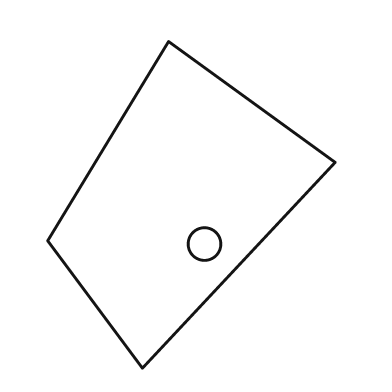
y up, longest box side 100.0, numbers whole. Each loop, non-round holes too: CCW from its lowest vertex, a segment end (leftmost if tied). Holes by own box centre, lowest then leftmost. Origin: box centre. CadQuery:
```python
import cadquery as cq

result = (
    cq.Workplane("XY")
    .moveTo(-15.0, -50.0)
    .lineTo(44.0, 13.0)
    .lineTo(-7.0, 50.0)
    .lineTo(-44.0, -11.0)
    .close()
    .moveTo(4.0, -12.0)
    .circle(5.0)
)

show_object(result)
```